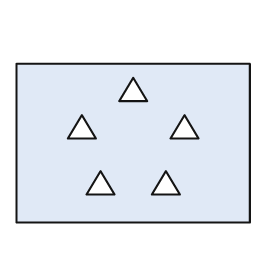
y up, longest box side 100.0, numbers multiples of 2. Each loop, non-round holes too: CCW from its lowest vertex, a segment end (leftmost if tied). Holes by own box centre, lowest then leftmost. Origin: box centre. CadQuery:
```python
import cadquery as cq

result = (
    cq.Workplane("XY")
    .moveTo(-50.0, -34.0)
    .lineTo(50.0, -34.0)
    .lineTo(50.0, 34.0)
    .lineTo(-50.0, 34.0)
    .close()
    .moveTo(-20.0, -22.0)
    .lineTo(-8.0, -22.0)
    .lineTo(-14.0, -12.0)
    .close()
    .moveTo(8.0, -22.0)
    .lineTo(20.0, -22.0)
    .lineTo(14.0, -12.0)
    .close()
    .moveTo(-28.0, 2.0)
    .lineTo(-16.0, 2.0)
    .lineTo(-22.0, 12.0)
    .close()
    .moveTo(16.0, 2.0)
    .lineTo(28.0, 2.0)
    .lineTo(22.0, 12.0)
    .close()
    .moveTo(-6.0, 18.0)
    .lineTo(6.0, 18.0)
    .lineTo(0.0, 28.0)
    .close()
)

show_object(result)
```